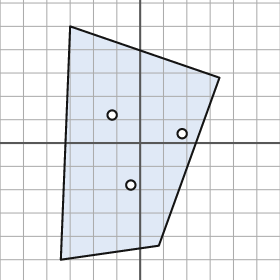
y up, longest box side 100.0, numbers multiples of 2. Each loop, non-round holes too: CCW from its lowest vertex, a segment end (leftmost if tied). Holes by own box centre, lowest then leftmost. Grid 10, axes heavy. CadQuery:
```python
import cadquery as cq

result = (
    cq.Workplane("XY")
    .moveTo(-34.0, -50.0)
    .lineTo(8.0, -44.0)
    .lineTo(34.0, 28.0)
    .lineTo(-30.0, 50.0)
    .close()
    .moveTo(-4.0, -18.0)
    .circle(2.0)
    .moveTo(18.0, 4.0)
    .circle(2.0)
    .moveTo(-12.0, 12.0)
    .circle(2.0)
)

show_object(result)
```